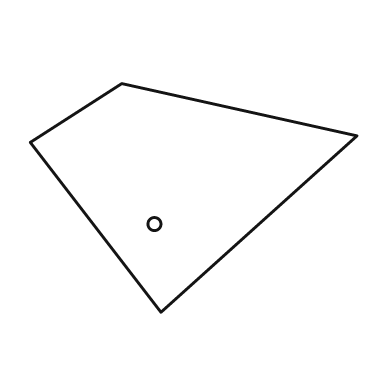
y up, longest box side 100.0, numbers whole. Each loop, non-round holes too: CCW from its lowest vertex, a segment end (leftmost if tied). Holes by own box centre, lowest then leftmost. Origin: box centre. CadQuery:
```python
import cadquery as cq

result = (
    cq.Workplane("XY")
    .moveTo(-10.0, -35.0)
    .lineTo(50.0, 19.0)
    .lineTo(-22.0, 35.0)
    .lineTo(-50.0, 17.0)
    .close()
    .moveTo(-12.0, -8.0)
    .circle(2.0)
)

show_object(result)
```